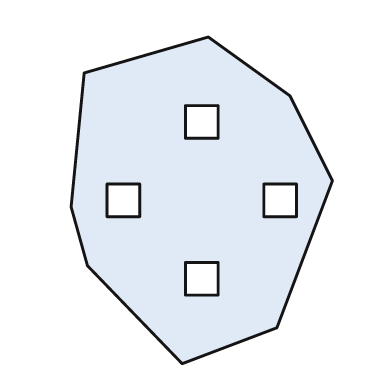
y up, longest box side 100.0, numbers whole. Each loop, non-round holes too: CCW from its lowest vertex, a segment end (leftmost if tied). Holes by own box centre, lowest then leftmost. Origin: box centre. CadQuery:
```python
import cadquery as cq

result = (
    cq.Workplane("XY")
    .moveTo(-6.0, -50.0)
    .lineTo(23.0, -39.0)
    .lineTo(40.0, 6.0)
    .lineTo(27.0, 32.0)
    .lineTo(2.0, 50.0)
    .lineTo(-36.0, 39.0)
    .lineTo(-40.0, -2.0)
    .lineTo(-35.0, -20.0)
    .close()
    .moveTo(-5.0, -29.0)
    .lineTo(5.0, -29.0)
    .lineTo(5.0, -19.0)
    .lineTo(-5.0, -19.0)
    .close()
    .moveTo(-29.0, -5.0)
    .lineTo(-19.0, -5.0)
    .lineTo(-19.0, 5.0)
    .lineTo(-29.0, 5.0)
    .close()
    .moveTo(19.0, -5.0)
    .lineTo(29.0, -5.0)
    .lineTo(29.0, 5.0)
    .lineTo(19.0, 5.0)
    .close()
    .moveTo(-5.0, 19.0)
    .lineTo(5.0, 19.0)
    .lineTo(5.0, 29.0)
    .lineTo(-5.0, 29.0)
    .close()
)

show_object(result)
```